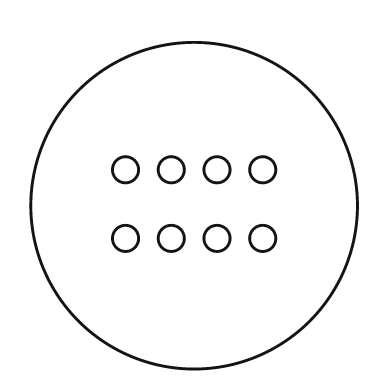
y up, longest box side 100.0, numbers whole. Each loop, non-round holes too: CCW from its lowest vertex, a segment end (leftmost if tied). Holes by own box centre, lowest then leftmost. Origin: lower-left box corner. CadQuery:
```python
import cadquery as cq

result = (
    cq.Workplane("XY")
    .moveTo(50.0, 50.0)
    .circle(50.0)
    .moveTo(29.0, 40.0)
    .circle(4.0)
    .moveTo(43.0, 40.0)
    .circle(4.0)
    .moveTo(57.0, 40.0)
    .circle(4.0)
    .moveTo(71.0, 40.0)
    .circle(4.0)
    .moveTo(29.0, 61.0)
    .circle(4.0)
    .moveTo(43.0, 61.0)
    .circle(4.0)
    .moveTo(57.0, 61.0)
    .circle(4.0)
    .moveTo(71.0, 61.0)
    .circle(4.0)
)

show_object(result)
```